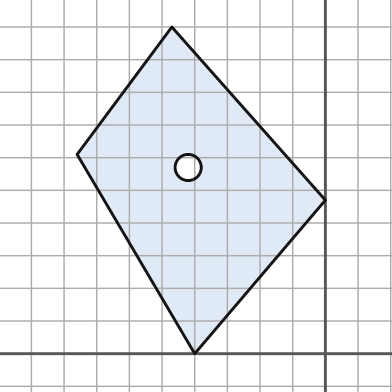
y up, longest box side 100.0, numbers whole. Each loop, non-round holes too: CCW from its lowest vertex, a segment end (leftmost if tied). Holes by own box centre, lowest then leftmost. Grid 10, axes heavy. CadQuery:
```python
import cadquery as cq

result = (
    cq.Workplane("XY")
    .moveTo(-40.0, 0.0)
    .lineTo(0.0, 47.0)
    .lineTo(-47.0, 100.0)
    .lineTo(-76.0, 61.0)
    .close()
    .moveTo(-42.0, 57.0)
    .circle(4.0)
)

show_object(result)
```